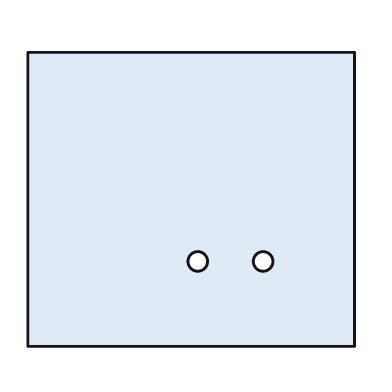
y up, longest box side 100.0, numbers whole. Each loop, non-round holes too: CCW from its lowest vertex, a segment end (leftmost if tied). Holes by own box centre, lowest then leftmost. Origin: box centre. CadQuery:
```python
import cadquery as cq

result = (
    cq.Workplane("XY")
    .moveTo(-50.0, -45.0)
    .lineTo(50.0, -45.0)
    .lineTo(50.0, 45.0)
    .lineTo(-50.0, 45.0)
    .close()
    .moveTo(2.0, -19.0)
    .circle(3.0)
    .moveTo(22.0, -19.0)
    .circle(3.0)
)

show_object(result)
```